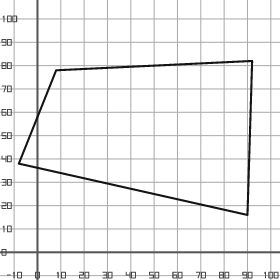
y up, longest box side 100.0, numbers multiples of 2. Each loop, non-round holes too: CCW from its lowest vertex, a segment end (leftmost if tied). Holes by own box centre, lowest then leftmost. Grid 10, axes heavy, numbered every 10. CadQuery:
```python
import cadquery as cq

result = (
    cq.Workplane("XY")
    .moveTo(90.0, 16.0)
    .lineTo(92.0, 82.0)
    .lineTo(8.0, 78.0)
    .lineTo(-8.0, 38.0)
    .close()
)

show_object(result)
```